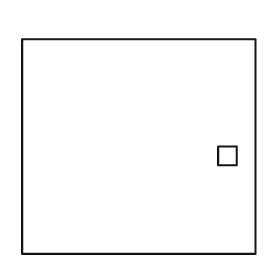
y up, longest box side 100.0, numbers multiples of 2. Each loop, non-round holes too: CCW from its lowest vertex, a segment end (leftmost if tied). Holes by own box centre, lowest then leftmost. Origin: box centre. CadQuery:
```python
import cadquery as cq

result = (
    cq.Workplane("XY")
    .moveTo(-50.0, -46.0)
    .lineTo(50.0, -46.0)
    .lineTo(50.0, 46.0)
    .lineTo(-50.0, 46.0)
    .close()
    .moveTo(34.0, -8.0)
    .lineTo(42.0, -8.0)
    .lineTo(42.0, 0.0)
    .lineTo(34.0, 0.0)
    .close()
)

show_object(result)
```